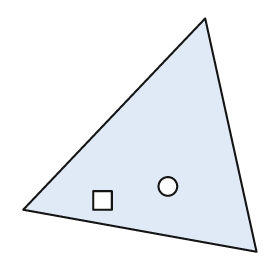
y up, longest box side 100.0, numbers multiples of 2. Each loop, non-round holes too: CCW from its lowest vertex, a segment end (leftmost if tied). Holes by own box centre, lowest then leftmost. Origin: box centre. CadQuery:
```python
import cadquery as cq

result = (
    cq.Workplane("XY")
    .moveTo(50.0, -50.0)
    .lineTo(28.0, 50.0)
    .lineTo(-50.0, -32.0)
    .close()
    .moveTo(-20.0, -32.0)
    .lineTo(-12.0, -32.0)
    .lineTo(-12.0, -24.0)
    .lineTo(-20.0, -24.0)
    .close()
    .moveTo(12.0, -22.0)
    .circle(4.0)
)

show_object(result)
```